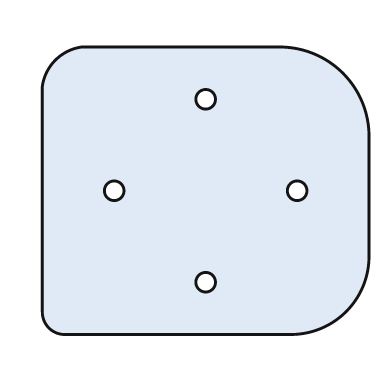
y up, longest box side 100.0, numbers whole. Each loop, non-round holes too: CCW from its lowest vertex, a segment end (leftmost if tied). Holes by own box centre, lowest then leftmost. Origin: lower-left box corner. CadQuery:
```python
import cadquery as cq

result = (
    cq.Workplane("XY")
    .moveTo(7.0, 0.0)
    .lineTo(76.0, 0.0)
    .threePointArc((93.0, 7.0), (100.0, 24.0))
    .lineTo(100.0, 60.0)
    .threePointArc((92.0, 80.0), (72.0, 88.0))
    .lineTo(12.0, 88.0)
    .threePointArc((4.0, 84.0), (0.0, 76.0))
    .lineTo(0.0, 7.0)
    .threePointArc((2.0, 2.0), (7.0, 0.0))
    .close()
    .moveTo(50.0, 16.0)
    .circle(3.0)
    .moveTo(22.0, 44.0)
    .circle(3.0)
    .moveTo(78.0, 44.0)
    .circle(3.0)
    .moveTo(50.0, 72.0)
    .circle(3.0)
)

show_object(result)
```